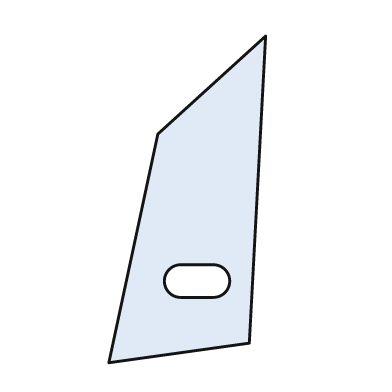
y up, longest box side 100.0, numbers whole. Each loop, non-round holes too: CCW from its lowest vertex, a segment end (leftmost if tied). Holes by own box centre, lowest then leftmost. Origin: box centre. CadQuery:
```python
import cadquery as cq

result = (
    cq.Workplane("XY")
    .moveTo(-24.0, -50.0)
    .lineTo(19.0, -44.0)
    .lineTo(24.0, 50.0)
    .lineTo(-9.0, 20.0)
    .close()
    .moveTo(-2.0, -30.0)
    .lineTo(8.0, -30.0)
    .threePointArc((13.0, -25.0), (8.0, -20.0))
    .lineTo(-2.0, -20.0)
    .threePointArc((-7.0, -25.0), (-2.0, -30.0))
    .close()
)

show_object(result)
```